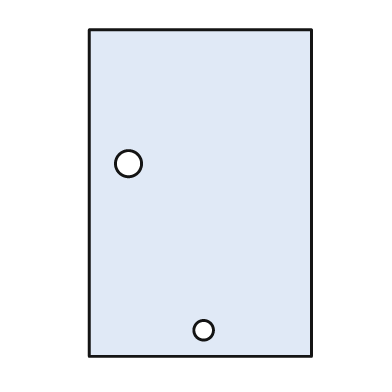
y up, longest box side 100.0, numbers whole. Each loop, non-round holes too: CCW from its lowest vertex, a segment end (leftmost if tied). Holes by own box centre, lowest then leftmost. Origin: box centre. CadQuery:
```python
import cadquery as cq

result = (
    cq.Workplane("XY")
    .moveTo(-34.0, -50.0)
    .lineTo(34.0, -50.0)
    .lineTo(34.0, 50.0)
    .lineTo(-34.0, 50.0)
    .close()
    .moveTo(1.0, -42.0)
    .circle(3.0)
    .moveTo(-22.0, 9.0)
    .circle(4.0)
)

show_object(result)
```